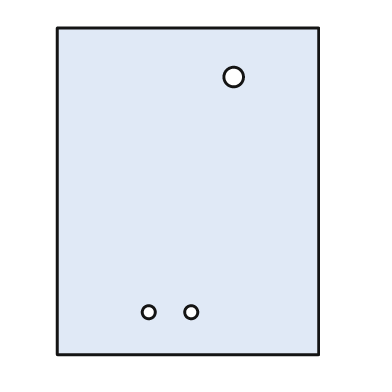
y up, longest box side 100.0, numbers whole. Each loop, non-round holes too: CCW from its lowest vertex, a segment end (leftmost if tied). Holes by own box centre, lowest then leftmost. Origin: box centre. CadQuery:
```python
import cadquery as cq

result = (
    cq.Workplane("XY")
    .moveTo(-40.0, -50.0)
    .lineTo(40.0, -50.0)
    .lineTo(40.0, 50.0)
    .lineTo(-40.0, 50.0)
    .close()
    .moveTo(-12.0, -37.0)
    .circle(2.0)
    .moveTo(1.0, -37.0)
    .circle(2.0)
    .moveTo(14.0, 35.0)
    .circle(3.0)
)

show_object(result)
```